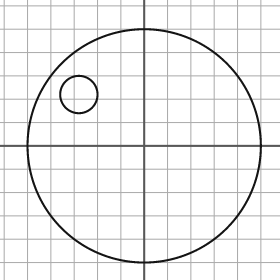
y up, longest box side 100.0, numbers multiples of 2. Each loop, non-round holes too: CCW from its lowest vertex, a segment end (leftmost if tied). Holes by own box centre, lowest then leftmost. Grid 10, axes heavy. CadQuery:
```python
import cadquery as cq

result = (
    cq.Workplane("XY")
    .moveTo(0.0, 0.0)
    .circle(50.0)
    .moveTo(-28.0, 22.0)
    .circle(8.0)
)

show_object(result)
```